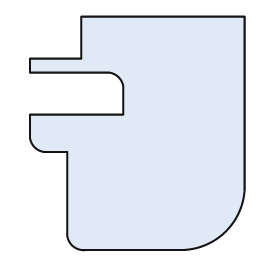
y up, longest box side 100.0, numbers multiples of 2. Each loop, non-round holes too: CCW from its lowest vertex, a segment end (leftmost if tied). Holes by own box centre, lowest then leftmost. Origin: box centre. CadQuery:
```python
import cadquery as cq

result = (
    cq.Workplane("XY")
    .moveTo(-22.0, -50.0)
    .lineTo(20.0, -50.0)
    .threePointArc((38.0, -42.0), (46.0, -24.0))
    .lineTo(46.0, 50.0)
    .lineTo(-24.0, 50.0)
    .lineTo(-24.0, 32.0)
    .lineTo(-46.0, 32.0)
    .lineTo(-46.0, 26.0)
    .lineTo(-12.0, 26.0)
    .threePointArc((-8.0, 24.0), (-6.0, 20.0))
    .lineTo(-6.0, 8.0)
    .lineTo(-46.0, 8.0)
    .lineTo(-46.0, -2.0)
    .threePointArc((-44.0, -6.0), (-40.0, -8.0))
    .lineTo(-30.0, -8.0)
    .lineTo(-30.0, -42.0)
    .threePointArc((-28.0, -48.0), (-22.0, -50.0))
    .close()
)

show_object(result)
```